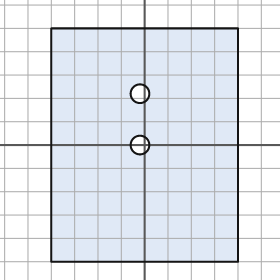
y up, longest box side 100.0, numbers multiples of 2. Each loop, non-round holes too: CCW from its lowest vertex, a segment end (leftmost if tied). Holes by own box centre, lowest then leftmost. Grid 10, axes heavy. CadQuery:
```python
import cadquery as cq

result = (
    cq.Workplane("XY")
    .moveTo(-40.0, -50.0)
    .lineTo(40.0, -50.0)
    .lineTo(40.0, 50.0)
    .lineTo(-40.0, 50.0)
    .close()
    .moveTo(-2.0, 0.0)
    .circle(4.0)
    .moveTo(-2.0, 22.0)
    .circle(4.0)
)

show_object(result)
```